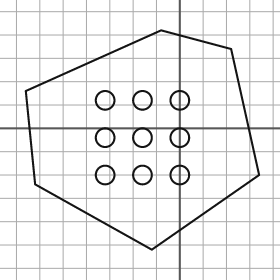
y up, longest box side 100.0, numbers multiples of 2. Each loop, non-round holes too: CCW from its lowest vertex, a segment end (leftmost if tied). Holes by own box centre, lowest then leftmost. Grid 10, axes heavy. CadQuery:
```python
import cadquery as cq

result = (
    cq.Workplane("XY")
    .moveTo(-12.0, -52.0)
    .lineTo(34.0, -20.0)
    .lineTo(22.0, 34.0)
    .lineTo(-8.0, 42.0)
    .lineTo(-66.0, 16.0)
    .lineTo(-62.0, -24.0)
    .close()
    .moveTo(-32.0, -20.0)
    .circle(4.0)
    .moveTo(-16.0, -20.0)
    .circle(4.0)
    .moveTo(0.0, -20.0)
    .circle(4.0)
    .moveTo(-32.0, -4.0)
    .circle(4.0)
    .moveTo(-16.0, -4.0)
    .circle(4.0)
    .moveTo(0.0, -4.0)
    .circle(4.0)
    .moveTo(-32.0, 12.0)
    .circle(4.0)
    .moveTo(-16.0, 12.0)
    .circle(4.0)
    .moveTo(0.0, 12.0)
    .circle(4.0)
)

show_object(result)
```